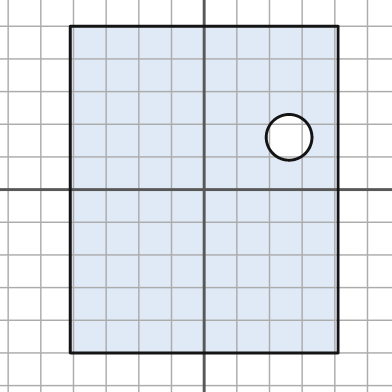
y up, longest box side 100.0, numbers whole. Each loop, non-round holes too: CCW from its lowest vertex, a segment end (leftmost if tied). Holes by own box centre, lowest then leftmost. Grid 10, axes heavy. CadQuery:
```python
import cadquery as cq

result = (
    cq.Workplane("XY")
    .moveTo(-41.0, -50.0)
    .lineTo(41.0, -50.0)
    .lineTo(41.0, 50.0)
    .lineTo(-41.0, 50.0)
    .close()
    .moveTo(26.0, 16.0)
    .circle(7.0)
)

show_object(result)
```